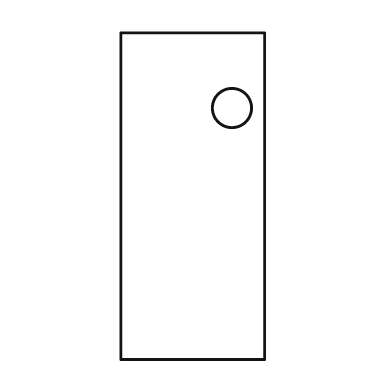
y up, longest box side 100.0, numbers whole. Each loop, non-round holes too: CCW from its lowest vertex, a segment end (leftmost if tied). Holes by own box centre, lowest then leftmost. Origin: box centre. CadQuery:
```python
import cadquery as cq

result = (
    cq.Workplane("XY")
    .moveTo(-22.0, -50.0)
    .lineTo(22.0, -50.0)
    .lineTo(22.0, 50.0)
    .lineTo(-22.0, 50.0)
    .close()
    .moveTo(12.0, 27.0)
    .circle(6.0)
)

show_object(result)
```